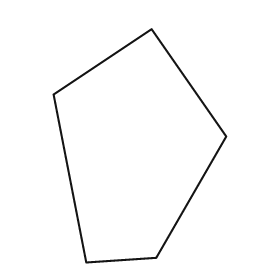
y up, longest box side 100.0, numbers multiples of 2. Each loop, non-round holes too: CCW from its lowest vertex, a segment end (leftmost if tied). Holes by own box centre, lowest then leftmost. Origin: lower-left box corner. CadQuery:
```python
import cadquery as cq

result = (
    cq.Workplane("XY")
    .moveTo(14.0, 0.0)
    .lineTo(44.0, 2.0)
    .lineTo(74.0, 54.0)
    .lineTo(42.0, 100.0)
    .lineTo(0.0, 72.0)
    .close()
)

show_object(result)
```